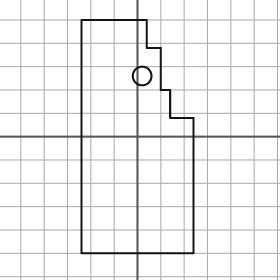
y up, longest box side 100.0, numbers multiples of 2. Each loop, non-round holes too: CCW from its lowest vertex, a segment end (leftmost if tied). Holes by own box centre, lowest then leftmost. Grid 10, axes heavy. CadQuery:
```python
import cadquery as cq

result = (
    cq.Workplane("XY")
    .moveTo(-24.0, -50.0)
    .lineTo(24.0, -50.0)
    .lineTo(24.0, 8.0)
    .lineTo(14.0, 8.0)
    .lineTo(14.0, 20.0)
    .lineTo(10.0, 20.0)
    .lineTo(10.0, 38.0)
    .lineTo(4.0, 38.0)
    .lineTo(4.0, 50.0)
    .lineTo(-24.0, 50.0)
    .close()
    .moveTo(2.0, 26.0)
    .circle(4.0)
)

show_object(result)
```